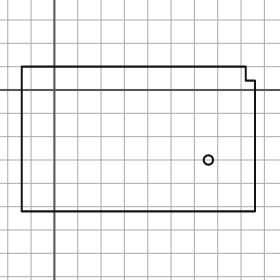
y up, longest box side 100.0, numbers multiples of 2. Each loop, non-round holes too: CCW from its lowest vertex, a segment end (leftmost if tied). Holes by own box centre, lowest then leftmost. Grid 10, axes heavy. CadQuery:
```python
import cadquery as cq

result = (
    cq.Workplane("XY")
    .moveTo(-14.0, -52.0)
    .lineTo(86.0, -52.0)
    .lineTo(86.0, 4.0)
    .lineTo(82.0, 4.0)
    .lineTo(82.0, 10.0)
    .lineTo(-14.0, 10.0)
    .close()
    .moveTo(66.0, -30.0)
    .circle(2.0)
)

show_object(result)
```